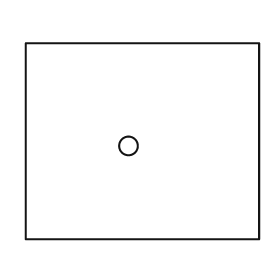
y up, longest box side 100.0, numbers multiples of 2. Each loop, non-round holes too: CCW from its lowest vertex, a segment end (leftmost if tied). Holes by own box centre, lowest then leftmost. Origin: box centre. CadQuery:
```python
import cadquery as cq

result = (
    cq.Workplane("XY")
    .moveTo(-50.0, -42.0)
    .lineTo(50.0, -42.0)
    .lineTo(50.0, 42.0)
    .lineTo(-50.0, 42.0)
    .close()
    .moveTo(-6.0, -2.0)
    .circle(4.0)
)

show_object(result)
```